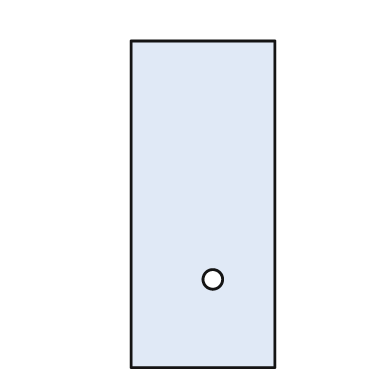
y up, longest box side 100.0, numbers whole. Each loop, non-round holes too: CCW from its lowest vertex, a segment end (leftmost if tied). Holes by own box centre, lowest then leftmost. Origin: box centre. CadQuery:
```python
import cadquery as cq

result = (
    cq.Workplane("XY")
    .moveTo(-22.0, -50.0)
    .lineTo(22.0, -50.0)
    .lineTo(22.0, 50.0)
    .lineTo(-22.0, 50.0)
    .close()
    .moveTo(3.0, -23.0)
    .circle(3.0)
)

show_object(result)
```